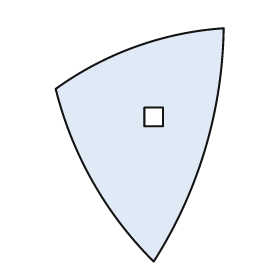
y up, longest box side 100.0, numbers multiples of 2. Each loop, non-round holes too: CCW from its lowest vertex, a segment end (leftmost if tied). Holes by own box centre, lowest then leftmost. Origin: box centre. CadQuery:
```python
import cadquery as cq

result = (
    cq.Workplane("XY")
    .moveTo(6.0, -50.0)
    .threePointArc((28.0, -2.0), (36.0, 50.0))
    .threePointArc((-2.0, 42.0), (-36.0, 24.0))
    .threePointArc((-20.0, -16.0), (6.0, -50.0))
    .close()
    .moveTo(2.0, 8.0)
    .lineTo(10.0, 8.0)
    .lineTo(10.0, 16.0)
    .lineTo(2.0, 16.0)
    .close()
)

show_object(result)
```